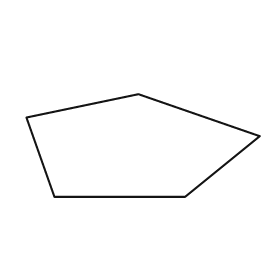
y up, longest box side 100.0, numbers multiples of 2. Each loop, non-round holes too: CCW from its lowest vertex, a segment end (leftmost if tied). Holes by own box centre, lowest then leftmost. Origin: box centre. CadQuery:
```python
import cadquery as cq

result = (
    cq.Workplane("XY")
    .moveTo(-38.0, -22.0)
    .lineTo(18.0, -22.0)
    .lineTo(50.0, 4.0)
    .lineTo(-2.0, 22.0)
    .lineTo(-50.0, 12.0)
    .close()
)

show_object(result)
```